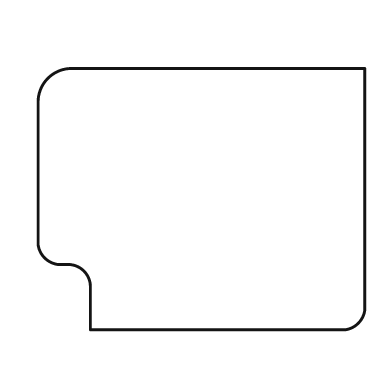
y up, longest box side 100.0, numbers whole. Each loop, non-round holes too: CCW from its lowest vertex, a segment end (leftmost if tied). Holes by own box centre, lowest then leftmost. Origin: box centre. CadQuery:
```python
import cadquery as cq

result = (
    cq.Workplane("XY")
    .moveTo(-34.0, -40.0)
    .lineTo(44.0, -40.0)
    .threePointArc((48.0, -38.0), (50.0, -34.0))
    .lineTo(50.0, 40.0)
    .lineTo(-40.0, 40.0)
    .threePointArc((-47.0, 37.0), (-50.0, 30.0))
    .lineTo(-50.0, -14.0)
    .threePointArc((-48.0, -18.0), (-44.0, -20.0))
    .lineTo(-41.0, -20.0)
    .threePointArc((-36.0, -22.0), (-34.0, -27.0))
    .close()
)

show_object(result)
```